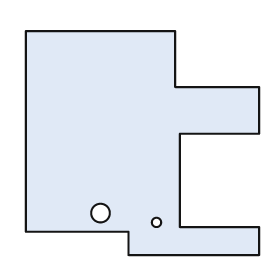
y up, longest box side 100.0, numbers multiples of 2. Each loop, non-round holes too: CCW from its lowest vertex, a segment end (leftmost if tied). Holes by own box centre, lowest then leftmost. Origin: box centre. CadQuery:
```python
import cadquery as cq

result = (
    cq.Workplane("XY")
    .moveTo(-6.0, -48.0)
    .lineTo(50.0, -48.0)
    .lineTo(50.0, -36.0)
    .lineTo(16.0, -36.0)
    .lineTo(16.0, 4.0)
    .lineTo(50.0, 4.0)
    .lineTo(50.0, 24.0)
    .lineTo(14.0, 24.0)
    .lineTo(14.0, 48.0)
    .lineTo(-50.0, 48.0)
    .lineTo(-50.0, -38.0)
    .lineTo(-6.0, -38.0)
    .close()
    .moveTo(6.0, -34.0)
    .circle(2.0)
    .moveTo(-18.0, -30.0)
    .circle(4.0)
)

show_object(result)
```